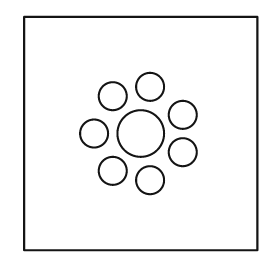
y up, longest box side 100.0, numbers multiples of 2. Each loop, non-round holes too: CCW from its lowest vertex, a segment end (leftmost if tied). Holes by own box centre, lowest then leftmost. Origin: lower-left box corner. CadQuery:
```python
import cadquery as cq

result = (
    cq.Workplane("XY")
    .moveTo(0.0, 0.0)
    .lineTo(100.0, 0.0)
    .lineTo(100.0, 100.0)
    .lineTo(0.0, 100.0)
    .close()
    .moveTo(54.0, 30.0)
    .circle(6.0)
    .moveTo(38.0, 34.0)
    .circle(6.0)
    .moveTo(68.0, 42.0)
    .circle(6.0)
    .moveTo(30.0, 50.0)
    .circle(6.0)
    .moveTo(50.0, 50.0)
    .circle(10.0)
    .moveTo(68.0, 58.0)
    .circle(6.0)
    .moveTo(38.0, 66.0)
    .circle(6.0)
    .moveTo(54.0, 70.0)
    .circle(6.0)
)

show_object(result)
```